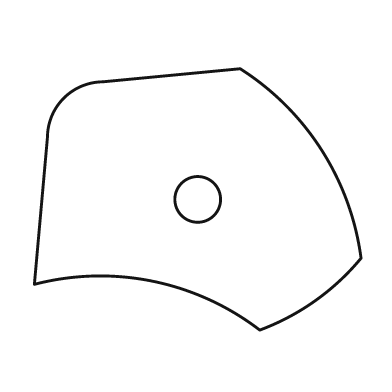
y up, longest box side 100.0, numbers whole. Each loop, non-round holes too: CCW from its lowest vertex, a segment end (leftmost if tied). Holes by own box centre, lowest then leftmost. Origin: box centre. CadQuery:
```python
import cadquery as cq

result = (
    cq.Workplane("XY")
    .moveTo(19.0, -40.0)
    .threePointArc((36.0, -31.0), (50.0, -18.0))
    .threePointArc((38.0, 15.0), (13.0, 40.0))
    .lineTo(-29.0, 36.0)
    .threePointArc((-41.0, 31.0), (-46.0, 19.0))
    .lineTo(-50.0, -26.0)
    .threePointArc((-14.0, -25.0), (19.0, -40.0))
    .close()
    .moveTo(0.0, 0.0)
    .circle(7.0)
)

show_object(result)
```